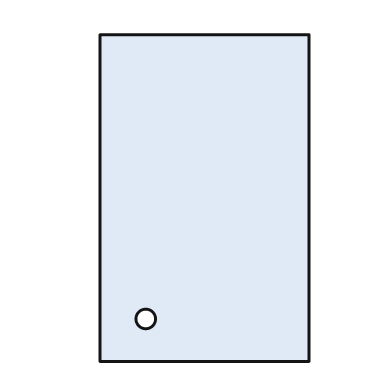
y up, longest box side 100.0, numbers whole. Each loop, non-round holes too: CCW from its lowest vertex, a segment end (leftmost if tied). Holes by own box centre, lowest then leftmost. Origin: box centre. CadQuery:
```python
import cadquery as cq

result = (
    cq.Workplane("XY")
    .moveTo(-32.0, -50.0)
    .lineTo(32.0, -50.0)
    .lineTo(32.0, 50.0)
    .lineTo(-32.0, 50.0)
    .close()
    .moveTo(-18.0, -37.0)
    .circle(3.0)
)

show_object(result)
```